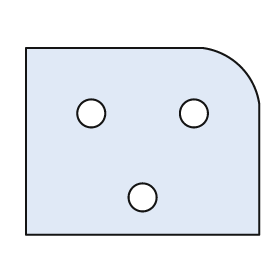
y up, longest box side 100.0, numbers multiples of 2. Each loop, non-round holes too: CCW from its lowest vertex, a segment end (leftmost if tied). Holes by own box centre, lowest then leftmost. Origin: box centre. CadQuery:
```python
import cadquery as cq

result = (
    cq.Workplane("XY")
    .moveTo(-50.0, -40.0)
    .lineTo(50.0, -40.0)
    .lineTo(50.0, 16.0)
    .threePointArc((42.0, 32.0), (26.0, 40.0))
    .lineTo(-50.0, 40.0)
    .close()
    .moveTo(0.0, -24.0)
    .circle(6.0)
    .moveTo(-22.0, 12.0)
    .circle(6.0)
    .moveTo(22.0, 12.0)
    .circle(6.0)
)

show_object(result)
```